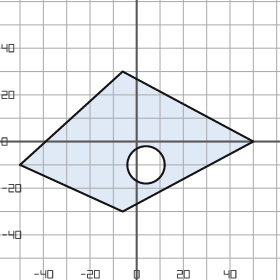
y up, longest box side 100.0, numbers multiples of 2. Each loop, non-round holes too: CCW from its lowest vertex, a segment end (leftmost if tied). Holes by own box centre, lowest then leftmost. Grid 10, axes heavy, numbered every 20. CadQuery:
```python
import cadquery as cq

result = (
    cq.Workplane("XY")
    .moveTo(-6.0, -30.0)
    .lineTo(50.0, 0.0)
    .lineTo(-6.0, 30.0)
    .lineTo(-50.0, -10.0)
    .close()
    .moveTo(4.0, -10.0)
    .circle(8.0)
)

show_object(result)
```